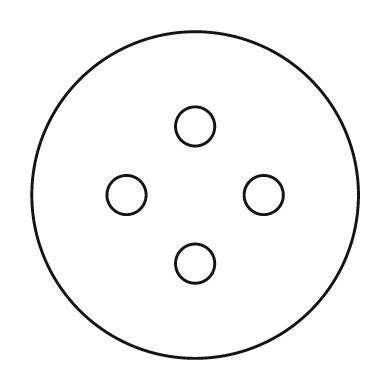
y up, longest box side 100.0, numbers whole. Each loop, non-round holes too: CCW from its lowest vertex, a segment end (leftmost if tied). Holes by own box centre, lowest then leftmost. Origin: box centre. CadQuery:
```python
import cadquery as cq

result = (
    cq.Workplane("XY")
    .moveTo(0.0, 0.0)
    .circle(50.0)
    .moveTo(0.0, -21.0)
    .circle(6.0)
    .moveTo(-21.0, 0.0)
    .circle(6.0)
    .moveTo(21.0, 0.0)
    .circle(6.0)
    .moveTo(0.0, 21.0)
    .circle(6.0)
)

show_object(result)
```